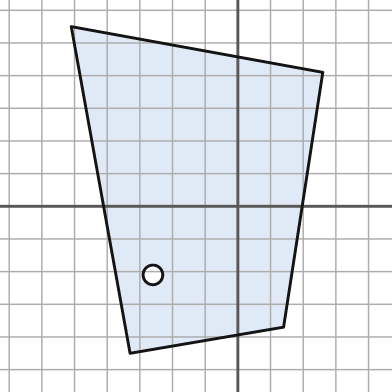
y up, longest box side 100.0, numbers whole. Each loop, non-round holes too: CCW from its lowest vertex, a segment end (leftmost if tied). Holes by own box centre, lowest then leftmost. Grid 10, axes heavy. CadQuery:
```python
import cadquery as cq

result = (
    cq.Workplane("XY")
    .moveTo(-33.0, -45.0)
    .lineTo(14.0, -37.0)
    .lineTo(26.0, 41.0)
    .lineTo(-51.0, 55.0)
    .close()
    .moveTo(-26.0, -21.0)
    .circle(3.0)
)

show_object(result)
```